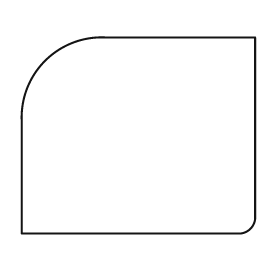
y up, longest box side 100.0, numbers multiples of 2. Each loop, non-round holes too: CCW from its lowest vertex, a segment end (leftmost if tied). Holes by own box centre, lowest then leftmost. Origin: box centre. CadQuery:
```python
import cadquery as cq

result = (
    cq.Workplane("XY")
    .moveTo(-50.0, -42.0)
    .lineTo(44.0, -42.0)
    .threePointArc((48.0, -40.0), (50.0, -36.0))
    .lineTo(50.0, 42.0)
    .lineTo(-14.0, 42.0)
    .threePointArc((-40.0, 32.0), (-50.0, 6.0))
    .close()
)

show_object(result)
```